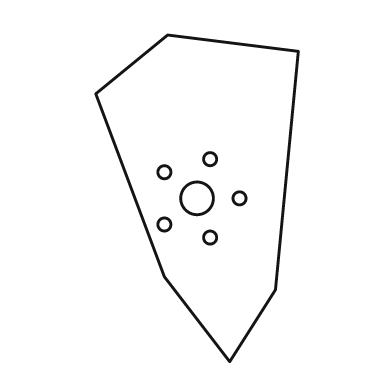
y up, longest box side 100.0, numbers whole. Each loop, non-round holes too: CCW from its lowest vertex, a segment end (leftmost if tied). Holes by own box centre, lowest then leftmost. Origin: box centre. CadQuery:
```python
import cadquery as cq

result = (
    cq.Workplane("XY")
    .moveTo(10.0, -50.0)
    .lineTo(24.0, -28.0)
    .lineTo(31.0, 45.0)
    .lineTo(-9.0, 50.0)
    .lineTo(-31.0, 32.0)
    .lineTo(-10.0, -24.0)
    .close()
    .moveTo(4.0, -12.0)
    .circle(2.0)
    .moveTo(-10.0, -8.0)
    .circle(2.0)
    .moveTo(0.0, 0.0)
    .circle(5.0)
    .moveTo(13.0, 0.0)
    .circle(2.0)
    .moveTo(-10.0, 8.0)
    .circle(2.0)
    .moveTo(4.0, 12.0)
    .circle(2.0)
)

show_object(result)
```